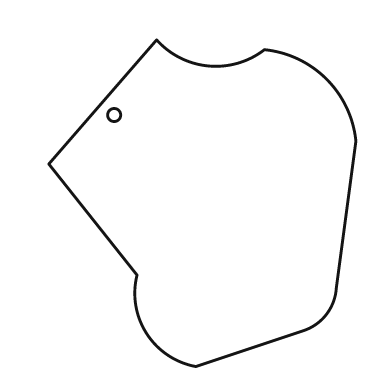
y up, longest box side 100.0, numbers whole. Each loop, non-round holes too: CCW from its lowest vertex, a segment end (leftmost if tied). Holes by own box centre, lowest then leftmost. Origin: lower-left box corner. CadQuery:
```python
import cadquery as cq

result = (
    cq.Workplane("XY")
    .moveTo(45.0, 0.0)
    .lineTo(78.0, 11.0)
    .threePointArc((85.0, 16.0), (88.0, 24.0))
    .lineTo(94.0, 69.0)
    .threePointArc((85.0, 88.0), (66.0, 97.0))
    .threePointArc((49.0, 92.0), (33.0, 100.0))
    .lineTo(0.0, 62.0)
    .lineTo(27.0, 28.0)
    .threePointArc((30.0, 10.0), (45.0, 0.0))
    .close()
    .moveTo(20.0, 77.0)
    .circle(2.0)
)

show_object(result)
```